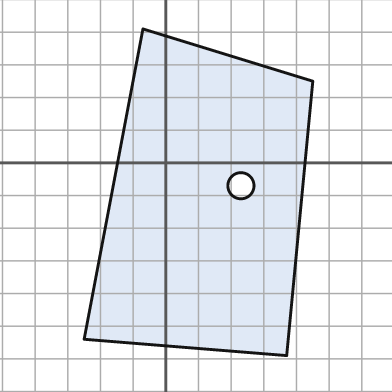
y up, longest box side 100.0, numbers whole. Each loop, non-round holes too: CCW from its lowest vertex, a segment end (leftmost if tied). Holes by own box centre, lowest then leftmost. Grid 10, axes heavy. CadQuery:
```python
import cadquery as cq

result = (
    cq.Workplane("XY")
    .moveTo(37.0, -59.0)
    .lineTo(45.0, 25.0)
    .lineTo(-7.0, 41.0)
    .lineTo(-25.0, -54.0)
    .close()
    .moveTo(23.0, -7.0)
    .circle(4.0)
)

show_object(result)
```